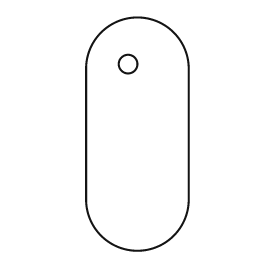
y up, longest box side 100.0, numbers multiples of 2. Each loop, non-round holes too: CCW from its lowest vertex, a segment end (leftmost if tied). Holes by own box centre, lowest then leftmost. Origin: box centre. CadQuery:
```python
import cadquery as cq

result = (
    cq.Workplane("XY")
    .moveTo(-22.0, -28.0)
    .threePointArc((0.0, -50.0), (22.0, -28.0))
    .lineTo(22.0, 28.0)
    .threePointArc((0.0, 50.0), (-22.0, 28.0))
    .close()
    .moveTo(-4.0, 30.0)
    .circle(4.0)
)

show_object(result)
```